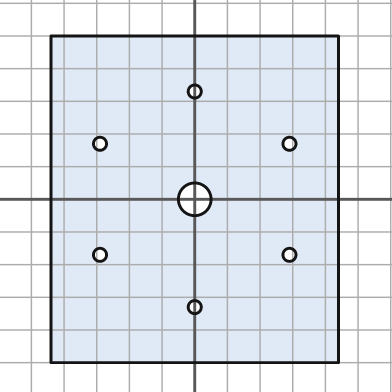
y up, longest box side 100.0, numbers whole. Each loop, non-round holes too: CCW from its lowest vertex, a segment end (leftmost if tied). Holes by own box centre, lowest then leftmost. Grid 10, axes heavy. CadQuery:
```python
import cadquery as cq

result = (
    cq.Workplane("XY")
    .moveTo(-44.0, -50.0)
    .lineTo(44.0, -50.0)
    .lineTo(44.0, 50.0)
    .lineTo(-44.0, 50.0)
    .close()
    .moveTo(0.0, -33.0)
    .circle(2.0)
    .moveTo(-29.0, -17.0)
    .circle(2.0)
    .moveTo(29.0, -17.0)
    .circle(2.0)
    .moveTo(0.0, 0.0)
    .circle(5.0)
    .moveTo(-29.0, 17.0)
    .circle(2.0)
    .moveTo(29.0, 17.0)
    .circle(2.0)
    .moveTo(0.0, 33.0)
    .circle(2.0)
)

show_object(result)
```